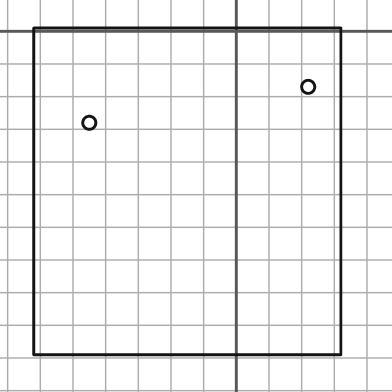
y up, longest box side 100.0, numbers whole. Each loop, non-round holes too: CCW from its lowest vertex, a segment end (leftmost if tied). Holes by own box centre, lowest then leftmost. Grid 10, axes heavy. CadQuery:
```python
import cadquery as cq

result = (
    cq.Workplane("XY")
    .moveTo(-62.0, -99.0)
    .lineTo(32.0, -99.0)
    .lineTo(32.0, 1.0)
    .lineTo(-62.0, 1.0)
    .close()
    .moveTo(-45.0, -28.0)
    .circle(2.0)
    .moveTo(22.0, -17.0)
    .circle(2.0)
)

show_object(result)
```